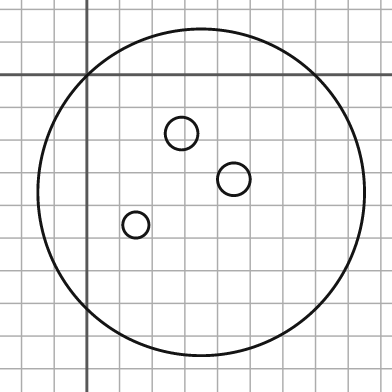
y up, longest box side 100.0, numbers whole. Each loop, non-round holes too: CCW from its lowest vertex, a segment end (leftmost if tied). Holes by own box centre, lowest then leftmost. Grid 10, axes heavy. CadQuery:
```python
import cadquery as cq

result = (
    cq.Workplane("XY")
    .moveTo(35.0, -36.0)
    .circle(50.0)
    .moveTo(15.0, -46.0)
    .circle(4.0)
    .moveTo(45.0, -32.0)
    .circle(5.0)
    .moveTo(29.0, -18.0)
    .circle(5.0)
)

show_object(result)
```